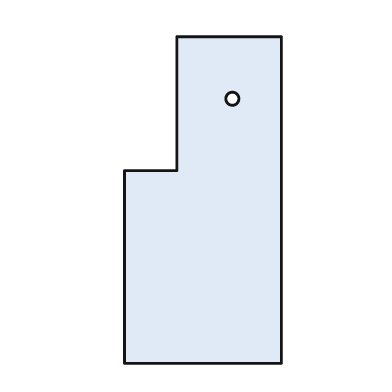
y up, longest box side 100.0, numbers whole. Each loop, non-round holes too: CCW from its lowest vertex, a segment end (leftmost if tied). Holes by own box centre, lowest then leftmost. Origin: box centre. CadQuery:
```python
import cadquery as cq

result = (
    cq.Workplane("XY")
    .moveTo(-24.0, -50.0)
    .lineTo(24.0, -50.0)
    .lineTo(24.0, 50.0)
    .lineTo(-8.0, 50.0)
    .lineTo(-8.0, 9.0)
    .lineTo(-24.0, 9.0)
    .close()
    .moveTo(9.0, 31.0)
    .circle(2.0)
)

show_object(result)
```